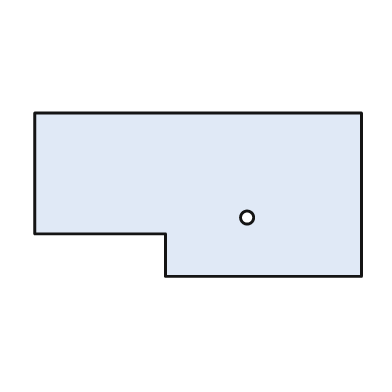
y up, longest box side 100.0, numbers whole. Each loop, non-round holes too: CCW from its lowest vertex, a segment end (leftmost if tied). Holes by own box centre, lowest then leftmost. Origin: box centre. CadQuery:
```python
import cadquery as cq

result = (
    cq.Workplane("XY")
    .moveTo(-10.0, -25.0)
    .lineTo(50.0, -25.0)
    .lineTo(50.0, 25.0)
    .lineTo(-50.0, 25.0)
    .lineTo(-50.0, -12.0)
    .lineTo(-10.0, -12.0)
    .close()
    .moveTo(15.0, -7.0)
    .circle(2.0)
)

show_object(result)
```